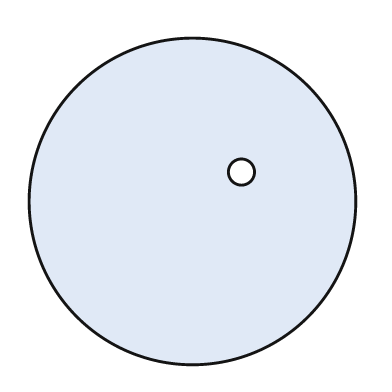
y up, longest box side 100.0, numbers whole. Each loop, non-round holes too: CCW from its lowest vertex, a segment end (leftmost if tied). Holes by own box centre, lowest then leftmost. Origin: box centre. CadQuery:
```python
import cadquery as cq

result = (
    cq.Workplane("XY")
    .moveTo(0.0, 0.0)
    .circle(50.0)
    .moveTo(15.0, 9.0)
    .circle(4.0)
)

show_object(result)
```